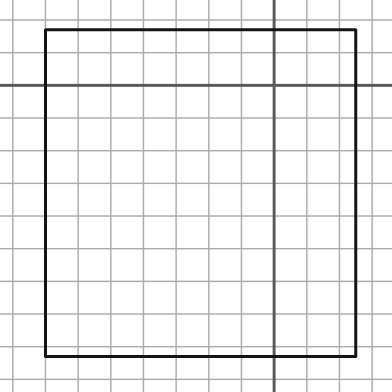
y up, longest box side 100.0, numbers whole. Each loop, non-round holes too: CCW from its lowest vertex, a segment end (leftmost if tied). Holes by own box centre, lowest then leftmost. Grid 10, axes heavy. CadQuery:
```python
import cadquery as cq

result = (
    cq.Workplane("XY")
    .moveTo(-70.0, -83.0)
    .lineTo(25.0, -83.0)
    .lineTo(25.0, 17.0)
    .lineTo(-70.0, 17.0)
    .close()
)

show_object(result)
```